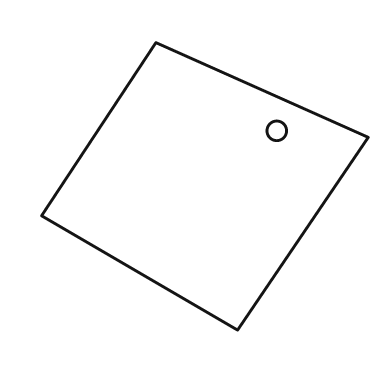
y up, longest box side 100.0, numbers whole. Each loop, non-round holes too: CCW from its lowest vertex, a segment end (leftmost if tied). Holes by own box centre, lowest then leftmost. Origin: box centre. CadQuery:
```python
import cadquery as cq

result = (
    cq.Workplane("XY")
    .moveTo(10.0, -44.0)
    .lineTo(50.0, 15.0)
    .lineTo(-15.0, 44.0)
    .lineTo(-50.0, -9.0)
    .close()
    .moveTo(22.0, 17.0)
    .circle(3.0)
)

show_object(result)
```